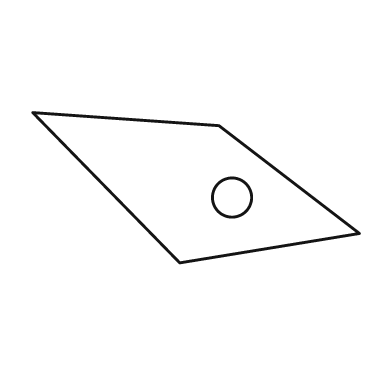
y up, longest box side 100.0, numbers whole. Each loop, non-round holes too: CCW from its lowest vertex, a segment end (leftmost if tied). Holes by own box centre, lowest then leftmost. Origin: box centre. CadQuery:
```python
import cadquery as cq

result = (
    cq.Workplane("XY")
    .moveTo(-5.0, -23.0)
    .lineTo(50.0, -14.0)
    .lineTo(7.0, 19.0)
    .lineTo(-50.0, 23.0)
    .close()
    .moveTo(11.0, -3.0)
    .circle(6.0)
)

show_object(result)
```